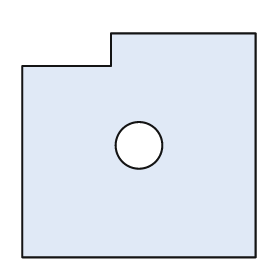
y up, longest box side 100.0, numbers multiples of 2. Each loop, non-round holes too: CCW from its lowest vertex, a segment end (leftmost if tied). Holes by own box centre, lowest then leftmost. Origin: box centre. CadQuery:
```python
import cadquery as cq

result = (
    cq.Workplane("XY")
    .moveTo(-50.0, -48.0)
    .lineTo(50.0, -48.0)
    .lineTo(50.0, 48.0)
    .lineTo(-12.0, 48.0)
    .lineTo(-12.0, 34.0)
    .lineTo(-50.0, 34.0)
    .close()
    .moveTo(0.0, 0.0)
    .circle(10.0)
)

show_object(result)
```